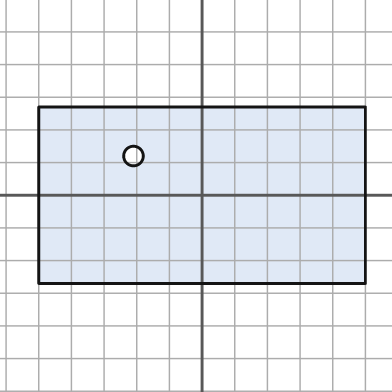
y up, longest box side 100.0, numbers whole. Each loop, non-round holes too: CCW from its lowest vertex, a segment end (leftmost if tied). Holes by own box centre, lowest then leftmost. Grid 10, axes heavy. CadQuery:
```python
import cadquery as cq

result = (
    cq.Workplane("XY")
    .moveTo(-50.0, -27.0)
    .lineTo(50.0, -27.0)
    .lineTo(50.0, 27.0)
    .lineTo(-50.0, 27.0)
    .close()
    .moveTo(-21.0, 12.0)
    .circle(3.0)
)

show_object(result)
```